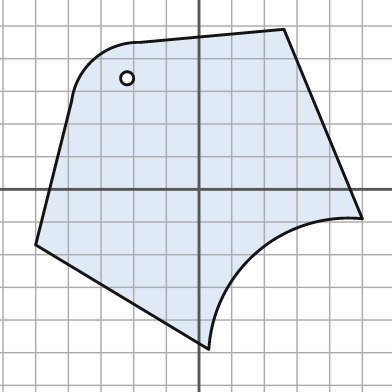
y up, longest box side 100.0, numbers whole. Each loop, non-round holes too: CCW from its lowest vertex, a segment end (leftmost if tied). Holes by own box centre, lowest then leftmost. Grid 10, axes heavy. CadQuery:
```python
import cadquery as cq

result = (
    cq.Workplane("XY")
    .moveTo(3.0, -49.0)
    .threePointArc((18.0, -19.0), (50.0, -9.0))
    .lineTo(26.0, 49.0)
    .lineTo(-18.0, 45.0)
    .threePointArc((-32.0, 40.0), (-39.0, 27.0))
    .lineTo(-50.0, -17.0)
    .close()
    .moveTo(-22.0, 34.0)
    .circle(2.0)
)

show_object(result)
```